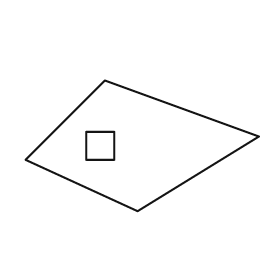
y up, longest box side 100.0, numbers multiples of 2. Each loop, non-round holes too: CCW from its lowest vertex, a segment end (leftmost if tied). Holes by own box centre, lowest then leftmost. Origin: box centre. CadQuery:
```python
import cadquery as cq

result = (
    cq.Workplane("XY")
    .moveTo(-2.0, -28.0)
    .lineTo(50.0, 4.0)
    .lineTo(-16.0, 28.0)
    .lineTo(-50.0, -6.0)
    .close()
    .moveTo(-24.0, -6.0)
    .lineTo(-12.0, -6.0)
    .lineTo(-12.0, 6.0)
    .lineTo(-24.0, 6.0)
    .close()
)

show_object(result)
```